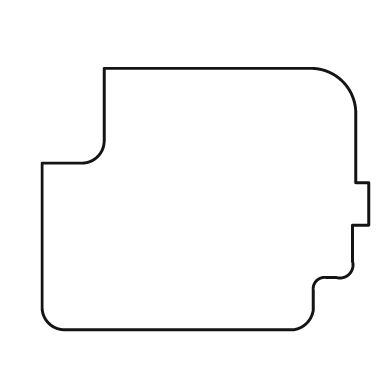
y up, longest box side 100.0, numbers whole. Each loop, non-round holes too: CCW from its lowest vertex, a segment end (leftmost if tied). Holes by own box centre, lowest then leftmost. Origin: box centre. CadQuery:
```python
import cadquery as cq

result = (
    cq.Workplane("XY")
    .moveTo(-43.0, -40.0)
    .lineTo(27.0, -40.0)
    .threePointArc((31.0, -38.0), (33.0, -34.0))
    .lineTo(33.0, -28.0)
    .threePointArc((34.0, -25.0), (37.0, -24.0))
    .lineTo(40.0, -24.0)
    .threePointArc((44.0, -23.0), (45.0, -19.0))
    .lineTo(45.0, -8.0)
    .lineTo(50.0, -8.0)
    .lineTo(50.0, 5.0)
    .lineTo(46.0, 5.0)
    .lineTo(46.0, 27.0)
    .threePointArc((42.0, 36.0), (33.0, 40.0))
    .lineTo(-31.0, 40.0)
    .lineTo(-31.0, 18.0)
    .threePointArc((-33.0, 13.0), (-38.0, 11.0))
    .lineTo(-50.0, 11.0)
    .lineTo(-50.0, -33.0)
    .threePointArc((-48.0, -38.0), (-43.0, -40.0))
    .close()
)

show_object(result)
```